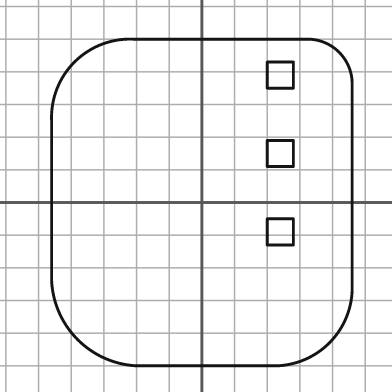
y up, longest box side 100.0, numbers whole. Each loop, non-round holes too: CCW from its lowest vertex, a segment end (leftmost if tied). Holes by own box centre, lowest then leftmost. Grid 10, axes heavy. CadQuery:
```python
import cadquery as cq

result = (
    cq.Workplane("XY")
    .moveTo(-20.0, -50.0)
    .lineTo(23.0, -50.0)
    .threePointArc((39.0, -43.0), (46.0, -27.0))
    .lineTo(46.0, 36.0)
    .threePointArc((42.0, 46.0), (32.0, 50.0))
    .lineTo(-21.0, 50.0)
    .threePointArc((-39.0, 43.0), (-46.0, 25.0))
    .lineTo(-46.0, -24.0)
    .threePointArc((-38.0, -42.0), (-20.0, -50.0))
    .close()
    .moveTo(20.0, -13.0)
    .lineTo(28.0, -13.0)
    .lineTo(28.0, -5.0)
    .lineTo(20.0, -5.0)
    .close()
    .moveTo(20.0, 11.0)
    .lineTo(28.0, 11.0)
    .lineTo(28.0, 19.0)
    .lineTo(20.0, 19.0)
    .close()
    .moveTo(20.0, 35.0)
    .lineTo(28.0, 35.0)
    .lineTo(28.0, 43.0)
    .lineTo(20.0, 43.0)
    .close()
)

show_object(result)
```